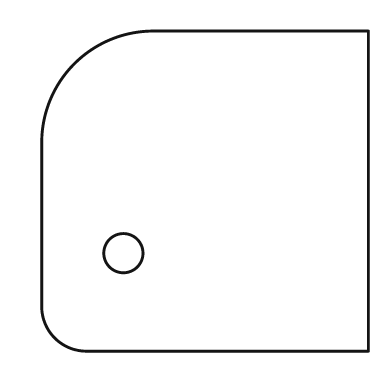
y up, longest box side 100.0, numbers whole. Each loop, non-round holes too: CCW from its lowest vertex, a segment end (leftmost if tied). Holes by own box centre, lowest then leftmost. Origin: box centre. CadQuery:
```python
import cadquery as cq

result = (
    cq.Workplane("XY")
    .moveTo(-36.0, -49.0)
    .lineTo(50.0, -49.0)
    .lineTo(50.0, 49.0)
    .lineTo(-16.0, 49.0)
    .threePointArc((-40.0, 39.0), (-50.0, 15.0))
    .lineTo(-50.0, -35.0)
    .threePointArc((-46.0, -45.0), (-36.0, -49.0))
    .close()
    .moveTo(-25.0, -19.0)
    .circle(6.0)
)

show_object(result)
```